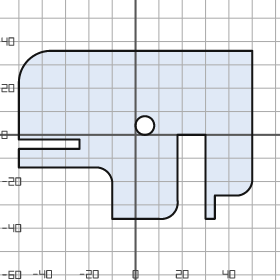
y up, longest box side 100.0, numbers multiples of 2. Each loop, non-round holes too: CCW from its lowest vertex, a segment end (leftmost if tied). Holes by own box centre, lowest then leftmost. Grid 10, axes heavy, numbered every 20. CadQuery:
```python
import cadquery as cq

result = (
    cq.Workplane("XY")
    .moveTo(-10.0, -36.0)
    .lineTo(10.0, -36.0)
    .threePointArc((16.0, -34.0), (18.0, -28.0))
    .lineTo(18.0, 0.0)
    .lineTo(30.0, 0.0)
    .lineTo(30.0, -36.0)
    .lineTo(34.0, -36.0)
    .lineTo(34.0, -26.0)
    .lineTo(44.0, -26.0)
    .threePointArc((48.0, -24.0), (50.0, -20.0))
    .lineTo(50.0, 36.0)
    .lineTo(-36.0, 36.0)
    .threePointArc((-46.0, 32.0), (-50.0, 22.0))
    .lineTo(-50.0, -2.0)
    .lineTo(-24.0, -2.0)
    .lineTo(-24.0, -6.0)
    .lineTo(-50.0, -6.0)
    .lineTo(-50.0, -14.0)
    .lineTo(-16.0, -14.0)
    .threePointArc((-12.0, -16.0), (-10.0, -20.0))
    .close()
    .moveTo(4.0, 4.0)
    .circle(4.0)
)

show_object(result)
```